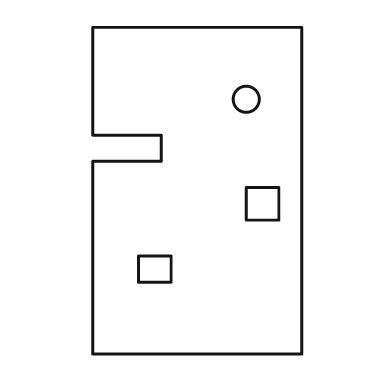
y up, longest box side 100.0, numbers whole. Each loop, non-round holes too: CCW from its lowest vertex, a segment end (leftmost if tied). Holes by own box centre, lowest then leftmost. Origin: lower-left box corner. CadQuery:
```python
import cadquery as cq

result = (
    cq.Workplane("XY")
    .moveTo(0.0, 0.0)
    .lineTo(64.0, 0.0)
    .lineTo(64.0, 100.0)
    .lineTo(0.0, 100.0)
    .lineTo(0.0, 67.0)
    .lineTo(21.0, 67.0)
    .lineTo(21.0, 59.0)
    .lineTo(0.0, 59.0)
    .close()
    .moveTo(14.0, 22.0)
    .lineTo(24.0, 22.0)
    .lineTo(24.0, 30.0)
    .lineTo(14.0, 30.0)
    .close()
    .moveTo(47.0, 41.0)
    .lineTo(57.0, 41.0)
    .lineTo(57.0, 51.0)
    .lineTo(47.0, 51.0)
    .close()
    .moveTo(47.0, 78.0)
    .circle(4.0)
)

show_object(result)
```